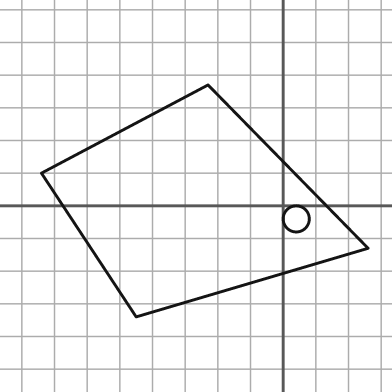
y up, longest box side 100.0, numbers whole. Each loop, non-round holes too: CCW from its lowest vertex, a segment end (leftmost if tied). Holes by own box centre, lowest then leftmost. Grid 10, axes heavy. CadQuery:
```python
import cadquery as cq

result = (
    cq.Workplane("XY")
    .moveTo(-45.0, -34.0)
    .lineTo(26.0, -13.0)
    .lineTo(-23.0, 37.0)
    .lineTo(-74.0, 10.0)
    .close()
    .moveTo(4.0, -4.0)
    .circle(4.0)
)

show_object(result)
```